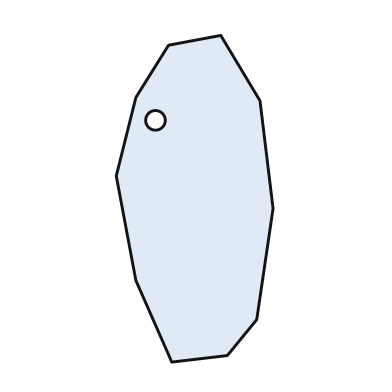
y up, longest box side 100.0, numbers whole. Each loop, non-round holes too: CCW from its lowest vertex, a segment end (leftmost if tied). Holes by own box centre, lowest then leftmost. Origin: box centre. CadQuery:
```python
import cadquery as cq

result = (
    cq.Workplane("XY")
    .moveTo(-7.0, -50.0)
    .lineTo(10.0, -48.0)
    .lineTo(19.0, -37.0)
    .lineTo(24.0, -3.0)
    .lineTo(20.0, 30.0)
    .lineTo(8.0, 50.0)
    .lineTo(-8.0, 47.0)
    .lineTo(-18.0, 31.0)
    .lineTo(-24.0, 7.0)
    .lineTo(-18.0, -25.0)
    .close()
    .moveTo(-12.0, 24.0)
    .circle(3.0)
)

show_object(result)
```